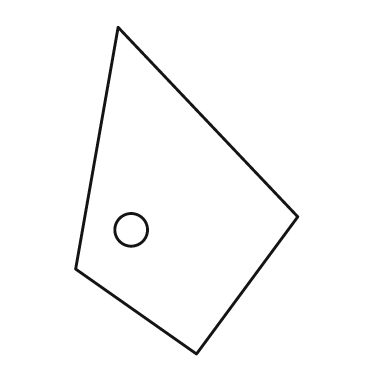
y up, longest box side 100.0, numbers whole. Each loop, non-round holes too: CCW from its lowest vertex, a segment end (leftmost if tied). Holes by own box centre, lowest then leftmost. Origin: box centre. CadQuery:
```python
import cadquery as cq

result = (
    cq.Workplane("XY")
    .moveTo(3.0, -50.0)
    .lineTo(34.0, -8.0)
    .lineTo(-21.0, 50.0)
    .lineTo(-34.0, -24.0)
    .close()
    .moveTo(-17.0, -12.0)
    .circle(5.0)
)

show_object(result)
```